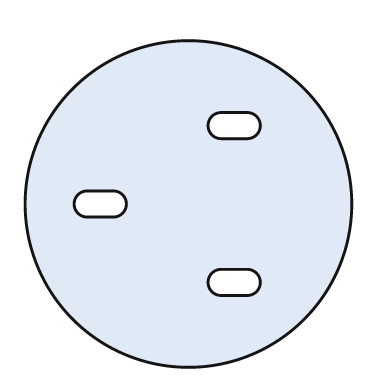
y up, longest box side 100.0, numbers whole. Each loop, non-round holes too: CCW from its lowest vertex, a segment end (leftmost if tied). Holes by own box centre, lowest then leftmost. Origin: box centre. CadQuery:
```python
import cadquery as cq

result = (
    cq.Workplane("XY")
    .moveTo(0.0, 0.0)
    .circle(50.0)
    .moveTo(10.0, -28.0)
    .lineTo(18.0, -28.0)
    .threePointArc((22.0, -24.0), (18.0, -20.0))
    .lineTo(10.0, -20.0)
    .threePointArc((6.0, -24.0), (10.0, -28.0))
    .close()
    .moveTo(-31.0, -4.0)
    .lineTo(-23.0, -4.0)
    .threePointArc((-19.0, 0.0), (-23.0, 4.0))
    .lineTo(-31.0, 4.0)
    .threePointArc((-35.0, 0.0), (-31.0, -4.0))
    .close()
    .moveTo(10.0, 20.0)
    .lineTo(18.0, 20.0)
    .threePointArc((22.0, 24.0), (18.0, 28.0))
    .lineTo(10.0, 28.0)
    .threePointArc((6.0, 24.0), (10.0, 20.0))
    .close()
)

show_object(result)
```